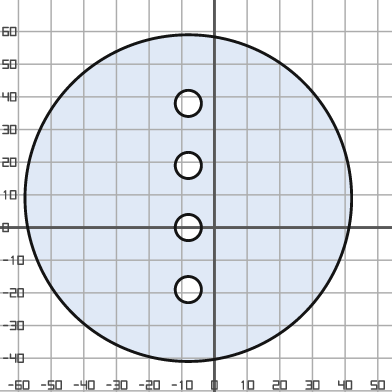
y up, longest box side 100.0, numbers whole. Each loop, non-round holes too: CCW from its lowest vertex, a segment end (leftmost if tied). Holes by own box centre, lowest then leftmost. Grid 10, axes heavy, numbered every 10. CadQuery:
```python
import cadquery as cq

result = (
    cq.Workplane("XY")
    .moveTo(-8.0, 9.0)
    .circle(50.0)
    .moveTo(-8.0, -19.0)
    .circle(4.0)
    .moveTo(-8.0, 0.0)
    .circle(4.0)
    .moveTo(-8.0, 19.0)
    .circle(4.0)
    .moveTo(-8.0, 38.0)
    .circle(4.0)
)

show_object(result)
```